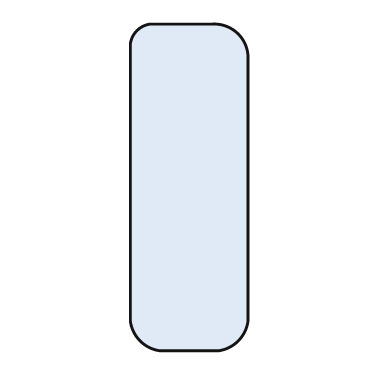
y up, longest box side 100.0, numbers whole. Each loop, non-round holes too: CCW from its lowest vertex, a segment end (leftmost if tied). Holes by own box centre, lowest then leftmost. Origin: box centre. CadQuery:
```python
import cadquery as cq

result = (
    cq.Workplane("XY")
    .moveTo(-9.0, -50.0)
    .lineTo(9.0, -50.0)
    .threePointArc((15.0, -47.0), (18.0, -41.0))
    .lineTo(18.0, 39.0)
    .threePointArc((15.0, 47.0), (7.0, 50.0))
    .lineTo(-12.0, 50.0)
    .threePointArc((-16.0, 48.0), (-18.0, 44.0))
    .lineTo(-18.0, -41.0)
    .threePointArc((-15.0, -47.0), (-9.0, -50.0))
    .close()
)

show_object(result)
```